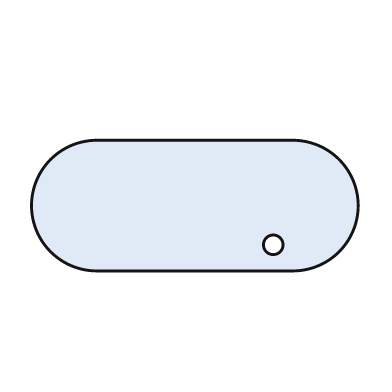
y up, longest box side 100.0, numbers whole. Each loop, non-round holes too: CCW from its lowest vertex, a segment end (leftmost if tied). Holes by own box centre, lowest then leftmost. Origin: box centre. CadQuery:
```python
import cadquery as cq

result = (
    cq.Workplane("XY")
    .moveTo(-30.0, -20.0)
    .lineTo(30.0, -20.0)
    .threePointArc((50.0, 0.0), (30.0, 20.0))
    .lineTo(-30.0, 20.0)
    .threePointArc((-50.0, 0.0), (-30.0, -20.0))
    .close()
    .moveTo(24.0, -12.0)
    .circle(3.0)
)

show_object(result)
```